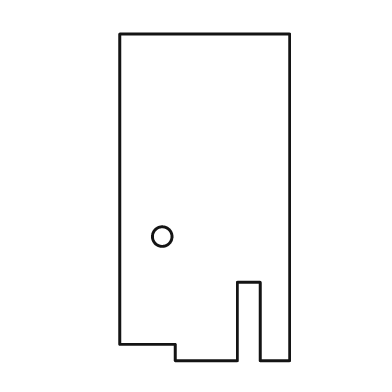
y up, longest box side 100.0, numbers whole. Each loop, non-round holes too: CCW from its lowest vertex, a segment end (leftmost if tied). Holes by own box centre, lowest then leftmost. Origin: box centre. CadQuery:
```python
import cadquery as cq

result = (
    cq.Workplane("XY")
    .moveTo(-9.0, -50.0)
    .lineTo(10.0, -50.0)
    .lineTo(10.0, -26.0)
    .lineTo(17.0, -26.0)
    .lineTo(17.0, -50.0)
    .lineTo(26.0, -50.0)
    .lineTo(26.0, 50.0)
    .lineTo(-26.0, 50.0)
    .lineTo(-26.0, -45.0)
    .lineTo(-9.0, -45.0)
    .close()
    .moveTo(-13.0, -12.0)
    .circle(3.0)
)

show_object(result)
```